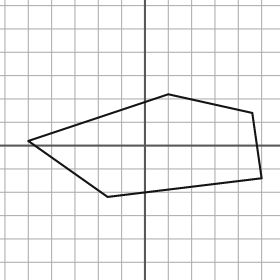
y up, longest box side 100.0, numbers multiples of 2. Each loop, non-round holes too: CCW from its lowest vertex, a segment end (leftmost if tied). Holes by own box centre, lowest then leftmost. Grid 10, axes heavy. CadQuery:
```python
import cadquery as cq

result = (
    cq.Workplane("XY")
    .moveTo(-16.0, -22.0)
    .lineTo(50.0, -14.0)
    .lineTo(46.0, 14.0)
    .lineTo(10.0, 22.0)
    .lineTo(-50.0, 2.0)
    .close()
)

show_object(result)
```